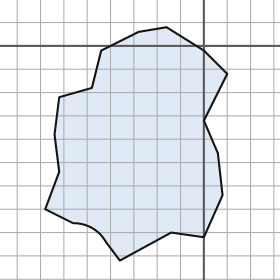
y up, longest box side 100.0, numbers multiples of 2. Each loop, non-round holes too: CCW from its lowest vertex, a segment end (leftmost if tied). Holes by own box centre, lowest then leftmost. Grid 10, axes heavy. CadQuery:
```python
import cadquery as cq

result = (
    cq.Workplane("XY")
    .moveTo(-36.0, -92.0)
    .lineTo(-14.0, -80.0)
    .lineTo(0.0, -82.0)
    .lineTo(8.0, -64.0)
    .lineTo(6.0, -46.0)
    .lineTo(0.0, -32.0)
    .lineTo(10.0, -12.0)
    .lineTo(0.0, -2.0)
    .lineTo(-16.0, 8.0)
    .lineTo(-28.0, 6.0)
    .lineTo(-44.0, -2.0)
    .lineTo(-48.0, -18.0)
    .lineTo(-62.0, -22.0)
    .lineTo(-64.0, -38.0)
    .lineTo(-62.0, -54.0)
    .lineTo(-68.0, -70.0)
    .lineTo(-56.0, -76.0)
    .threePointArc((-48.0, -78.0), (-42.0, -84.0))
    .close()
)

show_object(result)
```